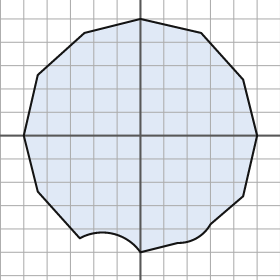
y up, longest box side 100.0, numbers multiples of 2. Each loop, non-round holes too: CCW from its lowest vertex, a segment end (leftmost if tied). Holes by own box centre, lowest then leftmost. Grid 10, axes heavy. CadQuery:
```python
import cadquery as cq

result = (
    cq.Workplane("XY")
    .moveTo(0.0, -50.0)
    .lineTo(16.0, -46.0)
    .threePointArc((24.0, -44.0), (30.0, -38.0))
    .lineTo(44.0, -26.0)
    .lineTo(50.0, 0.0)
    .lineTo(44.0, 24.0)
    .lineTo(26.0, 44.0)
    .lineTo(0.0, 50.0)
    .lineTo(-24.0, 44.0)
    .lineTo(-44.0, 26.0)
    .lineTo(-50.0, 0.0)
    .lineTo(-44.0, -24.0)
    .lineTo(-26.0, -44.0)
    .threePointArc((-12.0, -42.0), (0.0, -50.0))
    .close()
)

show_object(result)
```